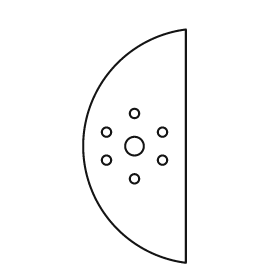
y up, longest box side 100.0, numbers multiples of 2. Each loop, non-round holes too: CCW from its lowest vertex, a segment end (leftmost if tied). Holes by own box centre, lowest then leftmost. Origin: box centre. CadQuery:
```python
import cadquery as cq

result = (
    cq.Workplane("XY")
    .moveTo(22.0, -50.0)
    .lineTo(22.0, 50.0)
    .threePointArc((-22.0, 0.0), (22.0, -50.0))
    .close()
    .moveTo(0.0, -14.0)
    .circle(2.0)
    .moveTo(-12.0, -6.0)
    .circle(2.0)
    .moveTo(12.0, -6.0)
    .circle(2.0)
    .moveTo(0.0, 0.0)
    .circle(4.0)
    .moveTo(-12.0, 6.0)
    .circle(2.0)
    .moveTo(12.0, 6.0)
    .circle(2.0)
    .moveTo(0.0, 14.0)
    .circle(2.0)
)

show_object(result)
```